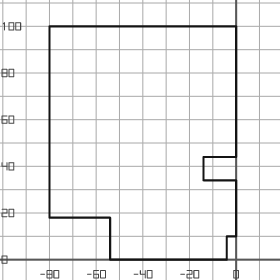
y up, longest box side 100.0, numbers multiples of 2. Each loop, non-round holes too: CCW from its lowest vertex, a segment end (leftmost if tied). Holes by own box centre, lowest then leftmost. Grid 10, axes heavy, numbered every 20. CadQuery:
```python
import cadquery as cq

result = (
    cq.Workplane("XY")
    .moveTo(-54.0, 0.0)
    .lineTo(-4.0, 0.0)
    .lineTo(-4.0, 10.0)
    .lineTo(0.0, 10.0)
    .lineTo(0.0, 34.0)
    .lineTo(-14.0, 34.0)
    .lineTo(-14.0, 44.0)
    .lineTo(0.0, 44.0)
    .lineTo(0.0, 100.0)
    .lineTo(-80.0, 100.0)
    .lineTo(-80.0, 18.0)
    .lineTo(-54.0, 18.0)
    .close()
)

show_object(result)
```